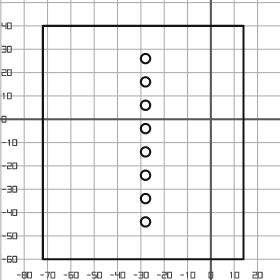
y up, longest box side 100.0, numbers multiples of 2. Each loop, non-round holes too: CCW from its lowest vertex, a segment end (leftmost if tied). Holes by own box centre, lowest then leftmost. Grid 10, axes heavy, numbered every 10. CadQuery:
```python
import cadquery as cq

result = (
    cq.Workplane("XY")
    .moveTo(-72.0, -60.0)
    .lineTo(14.0, -60.0)
    .lineTo(14.0, 40.0)
    .lineTo(-72.0, 40.0)
    .close()
    .moveTo(-28.0, -44.0)
    .circle(2.0)
    .moveTo(-28.0, -34.0)
    .circle(2.0)
    .moveTo(-28.0, -24.0)
    .circle(2.0)
    .moveTo(-28.0, -14.0)
    .circle(2.0)
    .moveTo(-28.0, -4.0)
    .circle(2.0)
    .moveTo(-28.0, 6.0)
    .circle(2.0)
    .moveTo(-28.0, 16.0)
    .circle(2.0)
    .moveTo(-28.0, 26.0)
    .circle(2.0)
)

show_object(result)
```